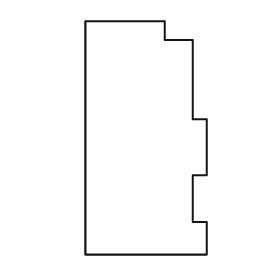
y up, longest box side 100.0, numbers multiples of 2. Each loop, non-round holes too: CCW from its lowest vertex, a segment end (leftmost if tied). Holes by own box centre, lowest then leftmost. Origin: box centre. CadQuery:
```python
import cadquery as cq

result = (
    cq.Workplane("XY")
    .moveTo(-26.0, -50.0)
    .lineTo(26.0, -50.0)
    .lineTo(26.0, -36.0)
    .lineTo(20.0, -36.0)
    .lineTo(20.0, -16.0)
    .lineTo(26.0, -16.0)
    .lineTo(26.0, 8.0)
    .lineTo(20.0, 8.0)
    .lineTo(20.0, 42.0)
    .lineTo(8.0, 42.0)
    .lineTo(8.0, 50.0)
    .lineTo(-26.0, 50.0)
    .close()
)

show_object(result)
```